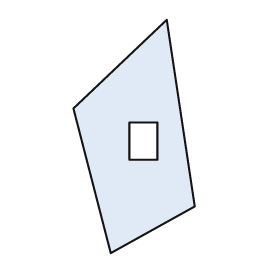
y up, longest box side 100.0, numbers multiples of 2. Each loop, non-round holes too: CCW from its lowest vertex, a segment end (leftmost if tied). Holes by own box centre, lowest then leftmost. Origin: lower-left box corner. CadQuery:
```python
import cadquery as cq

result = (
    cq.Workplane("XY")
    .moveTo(16.0, 0.0)
    .lineTo(52.0, 20.0)
    .lineTo(40.0, 100.0)
    .lineTo(0.0, 62.0)
    .close()
    .moveTo(24.0, 40.0)
    .lineTo(36.0, 40.0)
    .lineTo(36.0, 56.0)
    .lineTo(24.0, 56.0)
    .close()
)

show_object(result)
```